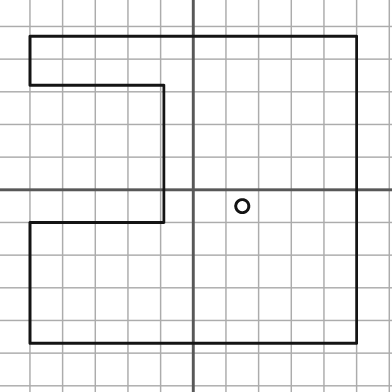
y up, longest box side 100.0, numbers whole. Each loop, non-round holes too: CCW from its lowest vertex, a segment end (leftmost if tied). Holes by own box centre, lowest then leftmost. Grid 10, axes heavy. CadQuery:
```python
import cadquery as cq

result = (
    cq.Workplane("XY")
    .moveTo(-50.0, -47.0)
    .lineTo(50.0, -47.0)
    .lineTo(50.0, 47.0)
    .lineTo(-50.0, 47.0)
    .lineTo(-50.0, 32.0)
    .lineTo(-9.0, 32.0)
    .lineTo(-9.0, -10.0)
    .lineTo(-50.0, -10.0)
    .close()
    .moveTo(15.0, -5.0)
    .circle(2.0)
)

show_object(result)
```